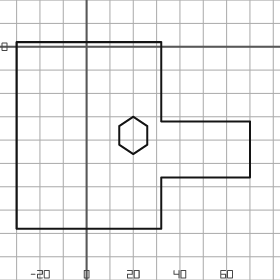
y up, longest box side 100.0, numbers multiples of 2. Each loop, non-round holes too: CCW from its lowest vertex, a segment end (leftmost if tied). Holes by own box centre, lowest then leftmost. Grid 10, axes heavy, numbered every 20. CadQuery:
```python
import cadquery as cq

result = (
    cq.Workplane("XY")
    .moveTo(-30.0, -78.0)
    .lineTo(32.0, -78.0)
    .lineTo(32.0, -56.0)
    .lineTo(70.0, -56.0)
    .lineTo(70.0, -32.0)
    .lineTo(32.0, -32.0)
    .lineTo(32.0, 2.0)
    .lineTo(-30.0, 2.0)
    .close()
    .moveTo(20.0, -46.0)
    .lineTo(26.0, -42.0)
    .lineTo(26.0, -34.0)
    .lineTo(20.0, -30.0)
    .lineTo(14.0, -34.0)
    .lineTo(14.0, -42.0)
    .close()
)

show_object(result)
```